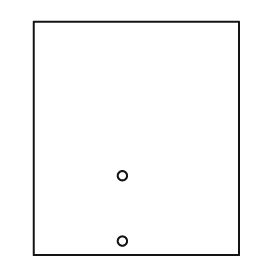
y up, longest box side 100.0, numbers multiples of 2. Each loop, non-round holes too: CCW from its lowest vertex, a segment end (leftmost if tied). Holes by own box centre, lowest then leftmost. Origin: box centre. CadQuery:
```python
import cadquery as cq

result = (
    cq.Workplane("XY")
    .moveTo(-44.0, -50.0)
    .lineTo(44.0, -50.0)
    .lineTo(44.0, 50.0)
    .lineTo(-44.0, 50.0)
    .close()
    .moveTo(-6.0, -44.0)
    .circle(2.0)
    .moveTo(-6.0, -16.0)
    .circle(2.0)
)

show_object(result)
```